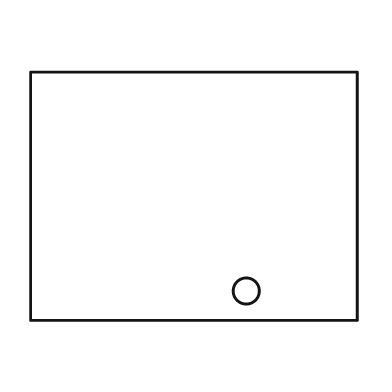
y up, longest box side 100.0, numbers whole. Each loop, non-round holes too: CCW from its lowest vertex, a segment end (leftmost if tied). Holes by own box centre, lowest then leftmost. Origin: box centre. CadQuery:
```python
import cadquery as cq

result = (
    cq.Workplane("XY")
    .moveTo(-50.0, -38.0)
    .lineTo(50.0, -38.0)
    .lineTo(50.0, 38.0)
    .lineTo(-50.0, 38.0)
    .close()
    .moveTo(16.0, -29.0)
    .circle(4.0)
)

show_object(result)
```